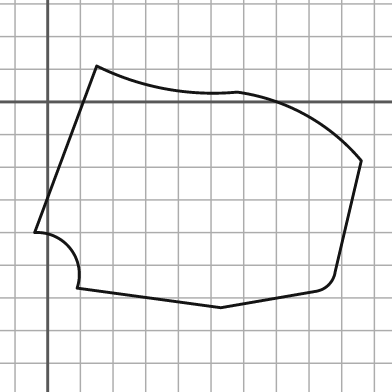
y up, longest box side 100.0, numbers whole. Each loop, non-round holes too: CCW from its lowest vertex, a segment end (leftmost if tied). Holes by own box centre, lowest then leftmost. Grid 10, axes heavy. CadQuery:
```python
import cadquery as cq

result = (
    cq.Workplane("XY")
    .moveTo(53.0, -63.0)
    .lineTo(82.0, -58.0)
    .threePointArc((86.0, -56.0), (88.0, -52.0))
    .lineTo(96.0, -18.0)
    .threePointArc((79.0, -4.0), (58.0, 3.0))
    .threePointArc((36.0, 4.0), (15.0, 11.0))
    .lineTo(-4.0, -40.0)
    .threePointArc((7.0, -45.0), (9.0, -57.0))
    .close()
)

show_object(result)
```